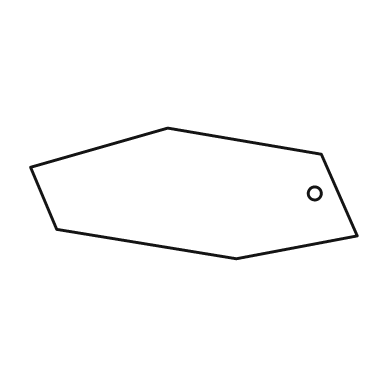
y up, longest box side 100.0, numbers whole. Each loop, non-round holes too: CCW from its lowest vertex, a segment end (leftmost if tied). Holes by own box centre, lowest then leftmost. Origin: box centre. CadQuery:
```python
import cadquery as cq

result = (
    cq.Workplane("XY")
    .moveTo(13.0, -20.0)
    .lineTo(50.0, -13.0)
    .lineTo(39.0, 12.0)
    .lineTo(-8.0, 20.0)
    .lineTo(-50.0, 8.0)
    .lineTo(-42.0, -11.0)
    .close()
    .moveTo(37.0, 0.0)
    .circle(2.0)
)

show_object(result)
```